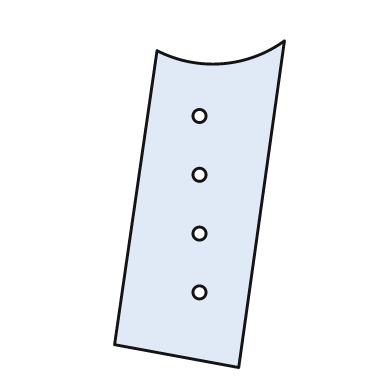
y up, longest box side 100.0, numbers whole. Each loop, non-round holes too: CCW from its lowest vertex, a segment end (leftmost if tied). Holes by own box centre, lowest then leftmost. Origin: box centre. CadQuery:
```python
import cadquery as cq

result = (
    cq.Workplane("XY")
    .moveTo(12.0, -50.0)
    .lineTo(26.0, 50.0)
    .threePointArc((7.0, 43.0), (-13.0, 47.0))
    .lineTo(-26.0, -43.0)
    .close()
    .moveTo(0.0, -27.0)
    .circle(2.0)
    .moveTo(0.0, -9.0)
    .circle(2.0)
    .moveTo(0.0, 9.0)
    .circle(2.0)
    .moveTo(0.0, 27.0)
    .circle(2.0)
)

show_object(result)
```